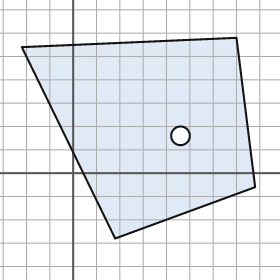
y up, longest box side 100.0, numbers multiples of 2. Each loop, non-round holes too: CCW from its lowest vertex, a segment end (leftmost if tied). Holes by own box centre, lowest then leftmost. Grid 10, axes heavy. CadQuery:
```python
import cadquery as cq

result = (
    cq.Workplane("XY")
    .moveTo(18.0, -28.0)
    .lineTo(78.0, -6.0)
    .lineTo(70.0, 58.0)
    .lineTo(-22.0, 54.0)
    .close()
    .moveTo(46.0, 16.0)
    .circle(4.0)
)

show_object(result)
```